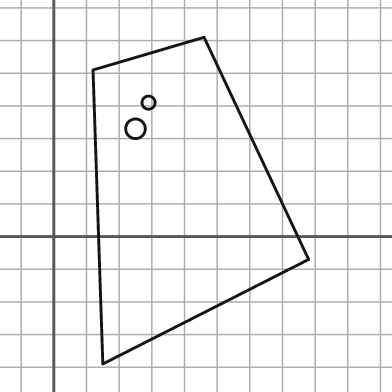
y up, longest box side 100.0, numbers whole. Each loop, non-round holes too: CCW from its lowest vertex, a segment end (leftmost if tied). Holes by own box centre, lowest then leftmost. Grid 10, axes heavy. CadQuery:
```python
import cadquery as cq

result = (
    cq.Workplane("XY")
    .moveTo(15.0, -39.0)
    .lineTo(78.0, -7.0)
    .lineTo(46.0, 61.0)
    .lineTo(12.0, 51.0)
    .close()
    .moveTo(25.0, 33.0)
    .circle(3.0)
    .moveTo(29.0, 41.0)
    .circle(2.0)
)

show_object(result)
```